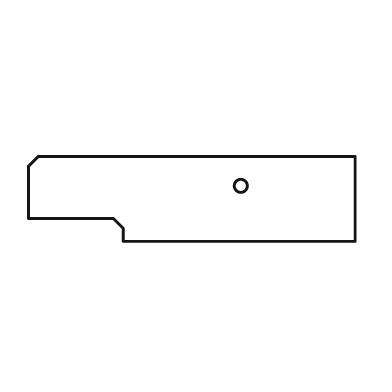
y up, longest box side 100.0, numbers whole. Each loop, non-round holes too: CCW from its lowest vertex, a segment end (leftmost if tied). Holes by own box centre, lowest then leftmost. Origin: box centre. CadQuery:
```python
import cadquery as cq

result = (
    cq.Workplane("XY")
    .moveTo(-21.0, -13.0)
    .lineTo(50.0, -13.0)
    .lineTo(50.0, 13.0)
    .lineTo(-47.0, 13.0)
    .lineTo(-50.0, 10.0)
    .lineTo(-50.0, -6.0)
    .lineTo(-24.0, -6.0)
    .lineTo(-21.0, -9.0)
    .close()
    .moveTo(15.0, 4.0)
    .circle(2.0)
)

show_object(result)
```